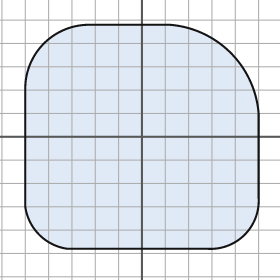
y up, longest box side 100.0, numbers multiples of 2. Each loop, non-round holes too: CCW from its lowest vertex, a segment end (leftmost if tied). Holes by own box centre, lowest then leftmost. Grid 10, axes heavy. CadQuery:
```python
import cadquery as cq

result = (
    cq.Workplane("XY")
    .moveTo(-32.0, -48.0)
    .lineTo(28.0, -48.0)
    .threePointArc((44.0, -42.0), (50.0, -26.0))
    .lineTo(50.0, 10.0)
    .threePointArc((38.0, 36.0), (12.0, 48.0))
    .lineTo(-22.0, 48.0)
    .threePointArc((-42.0, 40.0), (-50.0, 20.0))
    .lineTo(-50.0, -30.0)
    .threePointArc((-44.0, -42.0), (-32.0, -48.0))
    .close()
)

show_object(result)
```